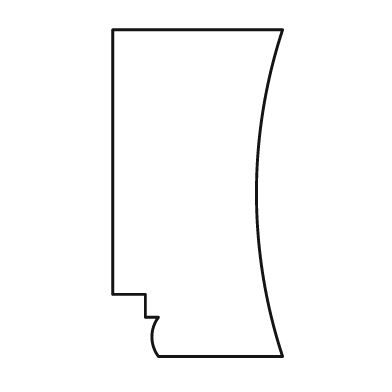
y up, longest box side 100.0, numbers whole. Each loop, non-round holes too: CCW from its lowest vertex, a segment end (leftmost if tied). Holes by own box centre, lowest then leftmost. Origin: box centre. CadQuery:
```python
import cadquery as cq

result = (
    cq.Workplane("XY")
    .moveTo(-12.0, -50.0)
    .lineTo(26.0, -50.0)
    .threePointArc((18.0, 0.0), (26.0, 50.0))
    .lineTo(-26.0, 50.0)
    .lineTo(-26.0, -31.0)
    .lineTo(-16.0, -31.0)
    .lineTo(-16.0, -38.0)
    .lineTo(-12.0, -38.0)
    .threePointArc((-14.0, -44.0), (-12.0, -50.0))
    .close()
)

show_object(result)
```